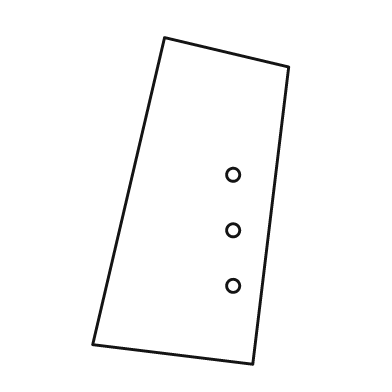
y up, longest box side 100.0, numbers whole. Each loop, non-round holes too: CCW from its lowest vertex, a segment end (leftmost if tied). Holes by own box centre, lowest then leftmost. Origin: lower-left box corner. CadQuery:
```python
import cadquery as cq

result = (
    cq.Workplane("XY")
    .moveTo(49.0, 0.0)
    .lineTo(60.0, 91.0)
    .lineTo(22.0, 100.0)
    .lineTo(0.0, 6.0)
    .close()
    .moveTo(43.0, 24.0)
    .circle(2.0)
    .moveTo(43.0, 41.0)
    .circle(2.0)
    .moveTo(43.0, 58.0)
    .circle(2.0)
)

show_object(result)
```